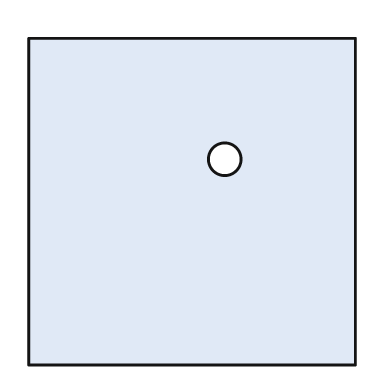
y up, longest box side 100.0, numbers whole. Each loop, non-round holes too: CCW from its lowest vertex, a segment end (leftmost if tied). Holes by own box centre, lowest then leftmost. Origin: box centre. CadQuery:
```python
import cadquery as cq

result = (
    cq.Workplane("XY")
    .moveTo(-50.0, -50.0)
    .lineTo(50.0, -50.0)
    .lineTo(50.0, 50.0)
    .lineTo(-50.0, 50.0)
    .close()
    .moveTo(10.0, 13.0)
    .circle(5.0)
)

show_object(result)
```